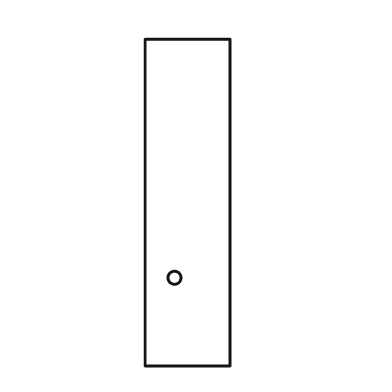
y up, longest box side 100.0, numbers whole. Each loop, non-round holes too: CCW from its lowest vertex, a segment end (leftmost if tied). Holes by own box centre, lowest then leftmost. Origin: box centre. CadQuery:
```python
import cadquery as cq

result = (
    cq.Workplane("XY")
    .moveTo(-13.0, -50.0)
    .lineTo(13.0, -50.0)
    .lineTo(13.0, 50.0)
    .lineTo(-13.0, 50.0)
    .close()
    .moveTo(-4.0, -23.0)
    .circle(2.0)
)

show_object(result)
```